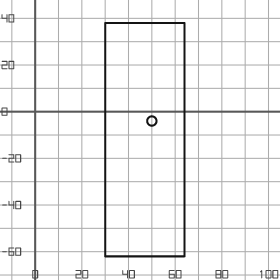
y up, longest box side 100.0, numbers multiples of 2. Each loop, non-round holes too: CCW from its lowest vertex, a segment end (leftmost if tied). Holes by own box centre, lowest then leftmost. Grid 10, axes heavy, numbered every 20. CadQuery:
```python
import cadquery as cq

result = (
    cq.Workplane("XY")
    .moveTo(30.0, -62.0)
    .lineTo(64.0, -62.0)
    .lineTo(64.0, 38.0)
    .lineTo(30.0, 38.0)
    .close()
    .moveTo(50.0, -4.0)
    .circle(2.0)
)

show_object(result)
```